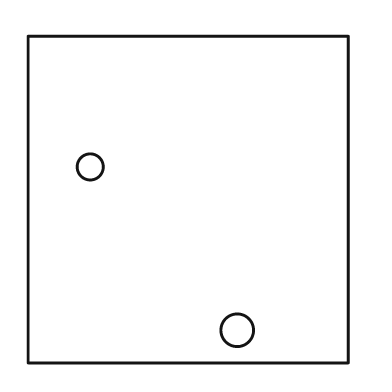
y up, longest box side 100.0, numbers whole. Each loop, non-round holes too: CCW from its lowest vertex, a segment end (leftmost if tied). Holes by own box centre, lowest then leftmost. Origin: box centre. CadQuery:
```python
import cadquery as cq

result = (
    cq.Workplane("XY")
    .moveTo(-49.0, -50.0)
    .lineTo(49.0, -50.0)
    .lineTo(49.0, 50.0)
    .lineTo(-49.0, 50.0)
    .close()
    .moveTo(15.0, -40.0)
    .circle(5.0)
    .moveTo(-30.0, 10.0)
    .circle(4.0)
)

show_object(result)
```